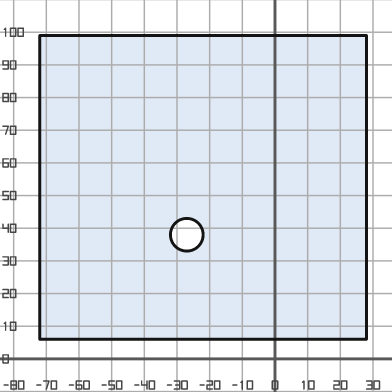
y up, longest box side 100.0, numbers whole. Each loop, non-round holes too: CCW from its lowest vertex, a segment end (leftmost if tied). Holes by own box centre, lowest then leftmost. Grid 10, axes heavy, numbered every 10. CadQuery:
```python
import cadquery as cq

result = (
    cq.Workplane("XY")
    .moveTo(-72.0, 6.0)
    .lineTo(28.0, 6.0)
    .lineTo(28.0, 99.0)
    .lineTo(-72.0, 99.0)
    .close()
    .moveTo(-27.0, 38.0)
    .circle(5.0)
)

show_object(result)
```